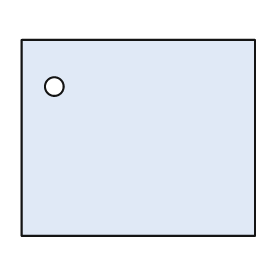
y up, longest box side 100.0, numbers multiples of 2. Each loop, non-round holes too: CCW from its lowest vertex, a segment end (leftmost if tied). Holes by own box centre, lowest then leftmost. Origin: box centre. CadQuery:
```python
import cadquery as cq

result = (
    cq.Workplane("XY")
    .moveTo(-50.0, -42.0)
    .lineTo(50.0, -42.0)
    .lineTo(50.0, 42.0)
    .lineTo(-50.0, 42.0)
    .close()
    .moveTo(-36.0, 22.0)
    .circle(4.0)
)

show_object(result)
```